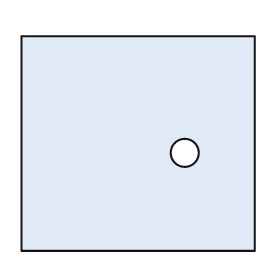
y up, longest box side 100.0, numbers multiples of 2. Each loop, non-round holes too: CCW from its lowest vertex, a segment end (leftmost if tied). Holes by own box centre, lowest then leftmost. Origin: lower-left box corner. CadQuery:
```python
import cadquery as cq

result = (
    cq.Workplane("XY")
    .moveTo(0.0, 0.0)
    .lineTo(100.0, 0.0)
    .lineTo(100.0, 92.0)
    .lineTo(0.0, 92.0)
    .close()
    .moveTo(70.0, 42.0)
    .circle(6.0)
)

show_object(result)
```